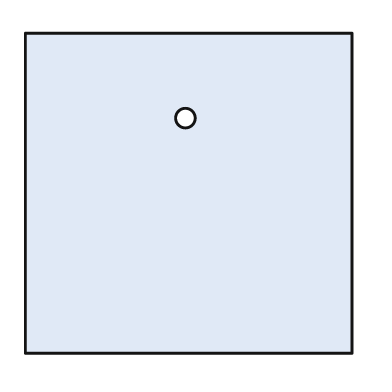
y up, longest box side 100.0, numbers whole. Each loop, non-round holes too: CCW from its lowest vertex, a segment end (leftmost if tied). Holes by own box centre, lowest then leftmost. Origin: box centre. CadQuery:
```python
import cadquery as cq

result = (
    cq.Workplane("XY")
    .moveTo(-50.0, -49.0)
    .lineTo(50.0, -49.0)
    .lineTo(50.0, 49.0)
    .lineTo(-50.0, 49.0)
    .close()
    .moveTo(-1.0, 23.0)
    .circle(3.0)
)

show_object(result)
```